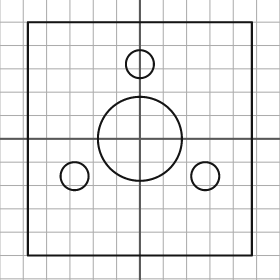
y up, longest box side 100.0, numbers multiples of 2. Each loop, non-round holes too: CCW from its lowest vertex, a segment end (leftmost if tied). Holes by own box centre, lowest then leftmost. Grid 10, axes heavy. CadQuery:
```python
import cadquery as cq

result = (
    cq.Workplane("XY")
    .moveTo(-48.0, -50.0)
    .lineTo(48.0, -50.0)
    .lineTo(48.0, 50.0)
    .lineTo(-48.0, 50.0)
    .close()
    .moveTo(-28.0, -16.0)
    .circle(6.0)
    .moveTo(28.0, -16.0)
    .circle(6.0)
    .moveTo(0.0, 0.0)
    .circle(18.0)
    .moveTo(0.0, 32.0)
    .circle(6.0)
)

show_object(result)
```